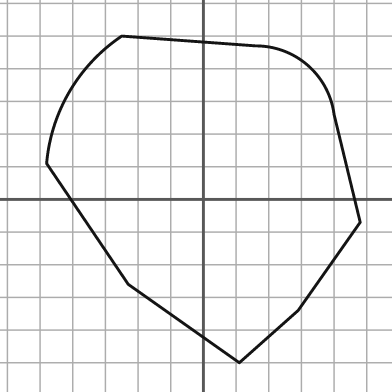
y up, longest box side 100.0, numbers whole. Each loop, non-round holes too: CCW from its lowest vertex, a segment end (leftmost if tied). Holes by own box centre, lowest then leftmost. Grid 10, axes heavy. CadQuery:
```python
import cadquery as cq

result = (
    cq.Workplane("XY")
    .moveTo(11.0, -50.0)
    .lineTo(29.0, -34.0)
    .lineTo(48.0, -7.0)
    .lineTo(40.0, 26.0)
    .threePointArc((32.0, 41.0), (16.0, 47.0))
    .lineTo(-25.0, 50.0)
    .threePointArc((-41.0, 33.0), (-48.0, 11.0))
    .lineTo(-23.0, -26.0)
    .close()
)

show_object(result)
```